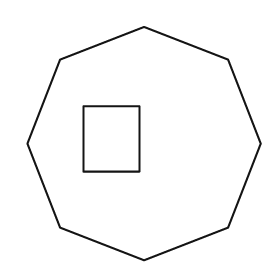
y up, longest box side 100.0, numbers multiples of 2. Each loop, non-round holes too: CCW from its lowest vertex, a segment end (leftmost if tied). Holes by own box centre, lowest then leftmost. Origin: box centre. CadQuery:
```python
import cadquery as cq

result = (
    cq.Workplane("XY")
    .moveTo(0.0, -50.0)
    .lineTo(36.0, -36.0)
    .lineTo(50.0, 0.0)
    .lineTo(36.0, 36.0)
    .lineTo(0.0, 50.0)
    .lineTo(-36.0, 36.0)
    .lineTo(-50.0, 0.0)
    .lineTo(-36.0, -36.0)
    .close()
    .moveTo(-26.0, -12.0)
    .lineTo(-2.0, -12.0)
    .lineTo(-2.0, 16.0)
    .lineTo(-26.0, 16.0)
    .close()
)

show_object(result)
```